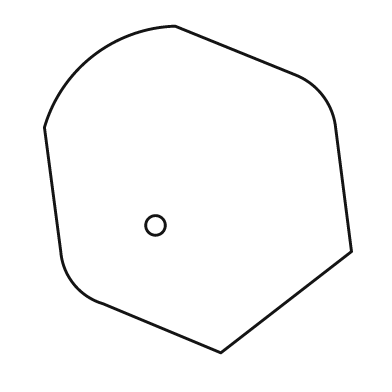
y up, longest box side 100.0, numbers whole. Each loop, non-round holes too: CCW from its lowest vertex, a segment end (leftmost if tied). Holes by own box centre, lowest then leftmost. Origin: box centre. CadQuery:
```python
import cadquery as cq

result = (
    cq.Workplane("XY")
    .moveTo(7.0, -50.0)
    .lineTo(47.0, -19.0)
    .lineTo(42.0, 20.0)
    .threePointArc((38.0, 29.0), (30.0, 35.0))
    .lineTo(-7.0, 50.0)
    .threePointArc((-32.0, 41.0), (-47.0, 19.0))
    .lineTo(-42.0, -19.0)
    .threePointArc((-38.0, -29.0), (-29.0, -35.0))
    .close()
    .moveTo(-13.0, -11.0)
    .circle(3.0)
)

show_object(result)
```